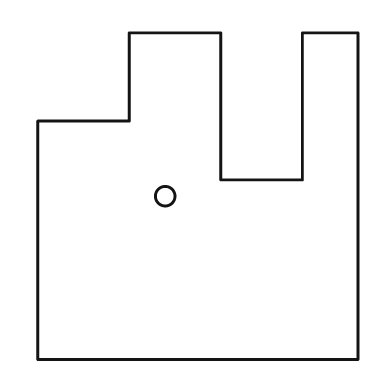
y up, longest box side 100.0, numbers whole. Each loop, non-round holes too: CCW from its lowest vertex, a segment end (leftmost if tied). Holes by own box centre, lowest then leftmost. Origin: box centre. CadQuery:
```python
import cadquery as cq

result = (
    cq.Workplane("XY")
    .moveTo(-49.0, -50.0)
    .lineTo(49.0, -50.0)
    .lineTo(49.0, 50.0)
    .lineTo(32.0, 50.0)
    .lineTo(32.0, 5.0)
    .lineTo(7.0, 5.0)
    .lineTo(7.0, 50.0)
    .lineTo(-21.0, 50.0)
    .lineTo(-21.0, 23.0)
    .lineTo(-49.0, 23.0)
    .close()
    .moveTo(-10.0, 0.0)
    .circle(3.0)
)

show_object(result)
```